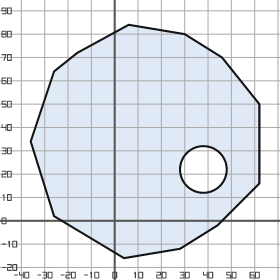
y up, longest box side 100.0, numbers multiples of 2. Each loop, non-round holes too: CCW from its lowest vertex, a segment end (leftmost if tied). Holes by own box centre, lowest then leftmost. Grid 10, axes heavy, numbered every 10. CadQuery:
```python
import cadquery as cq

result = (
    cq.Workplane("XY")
    .moveTo(4.0, -16.0)
    .lineTo(28.0, -12.0)
    .lineTo(44.0, -2.0)
    .lineTo(62.0, 16.0)
    .lineTo(62.0, 50.0)
    .lineTo(46.0, 70.0)
    .lineTo(30.0, 80.0)
    .lineTo(6.0, 84.0)
    .lineTo(-16.0, 72.0)
    .lineTo(-26.0, 64.0)
    .lineTo(-36.0, 34.0)
    .lineTo(-26.0, 2.0)
    .close()
    .moveTo(38.0, 22.0)
    .circle(10.0)
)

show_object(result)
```